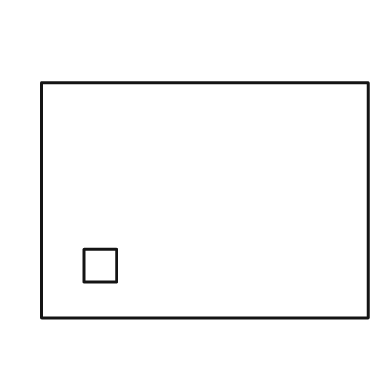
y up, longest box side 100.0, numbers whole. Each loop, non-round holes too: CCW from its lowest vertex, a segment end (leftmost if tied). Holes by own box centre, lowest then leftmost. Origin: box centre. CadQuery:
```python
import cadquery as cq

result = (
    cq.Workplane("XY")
    .moveTo(-50.0, -36.0)
    .lineTo(50.0, -36.0)
    .lineTo(50.0, 36.0)
    .lineTo(-50.0, 36.0)
    .close()
    .moveTo(-37.0, -25.0)
    .lineTo(-27.0, -25.0)
    .lineTo(-27.0, -15.0)
    .lineTo(-37.0, -15.0)
    .close()
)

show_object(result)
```